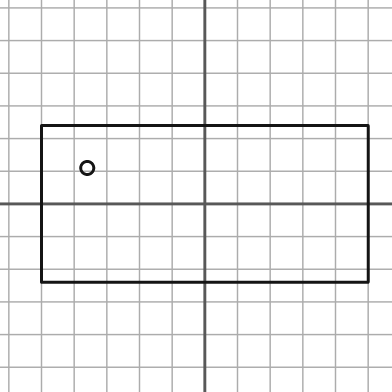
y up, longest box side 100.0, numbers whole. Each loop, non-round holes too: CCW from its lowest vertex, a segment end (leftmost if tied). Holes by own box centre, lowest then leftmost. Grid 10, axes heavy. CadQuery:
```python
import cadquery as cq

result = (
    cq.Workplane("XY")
    .moveTo(-50.0, -24.0)
    .lineTo(50.0, -24.0)
    .lineTo(50.0, 24.0)
    .lineTo(-50.0, 24.0)
    .close()
    .moveTo(-36.0, 11.0)
    .circle(2.0)
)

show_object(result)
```